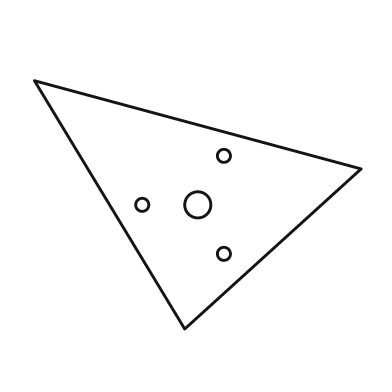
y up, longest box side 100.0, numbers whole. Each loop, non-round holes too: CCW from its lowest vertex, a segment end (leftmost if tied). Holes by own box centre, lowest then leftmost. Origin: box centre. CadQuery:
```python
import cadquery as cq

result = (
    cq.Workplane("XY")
    .moveTo(-4.0, -38.0)
    .lineTo(50.0, 11.0)
    .lineTo(-50.0, 38.0)
    .close()
    .moveTo(8.0, -15.0)
    .circle(2.0)
    .moveTo(-17.0, 0.0)
    .circle(2.0)
    .moveTo(0.0, 0.0)
    .circle(4.0)
    .moveTo(8.0, 15.0)
    .circle(2.0)
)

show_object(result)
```